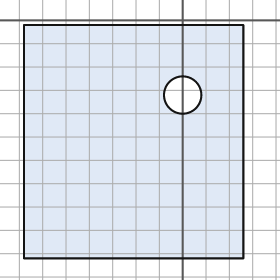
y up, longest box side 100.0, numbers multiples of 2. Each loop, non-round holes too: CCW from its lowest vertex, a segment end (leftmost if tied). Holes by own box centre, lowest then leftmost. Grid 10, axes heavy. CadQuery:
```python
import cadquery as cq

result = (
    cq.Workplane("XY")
    .moveTo(-68.0, -102.0)
    .lineTo(26.0, -102.0)
    .lineTo(26.0, -2.0)
    .lineTo(-68.0, -2.0)
    .close()
    .moveTo(0.0, -32.0)
    .circle(8.0)
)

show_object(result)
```